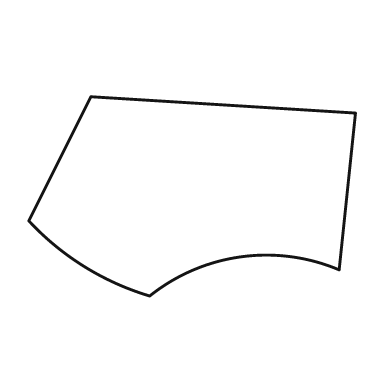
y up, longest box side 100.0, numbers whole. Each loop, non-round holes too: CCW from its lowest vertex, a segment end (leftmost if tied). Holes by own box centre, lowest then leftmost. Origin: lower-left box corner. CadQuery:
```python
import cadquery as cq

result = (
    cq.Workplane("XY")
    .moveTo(37.0, 0.0)
    .threePointArc((65.0, 12.0), (95.0, 8.0))
    .lineTo(100.0, 56.0)
    .lineTo(19.0, 61.0)
    .lineTo(0.0, 23.0)
    .threePointArc((17.0, 9.0), (37.0, 0.0))
    .close()
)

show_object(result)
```